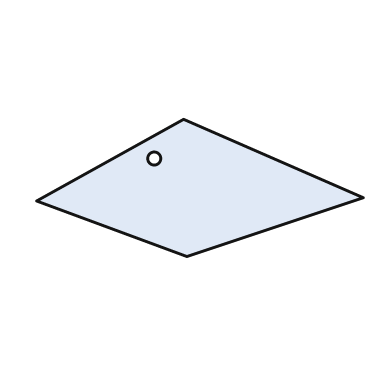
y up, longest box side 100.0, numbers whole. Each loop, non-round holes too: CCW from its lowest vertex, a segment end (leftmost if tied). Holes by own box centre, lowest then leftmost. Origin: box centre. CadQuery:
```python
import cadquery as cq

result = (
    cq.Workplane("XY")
    .moveTo(-4.0, -21.0)
    .lineTo(50.0, -3.0)
    .lineTo(-5.0, 21.0)
    .lineTo(-50.0, -4.0)
    .close()
    .moveTo(-14.0, 9.0)
    .circle(2.0)
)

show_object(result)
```